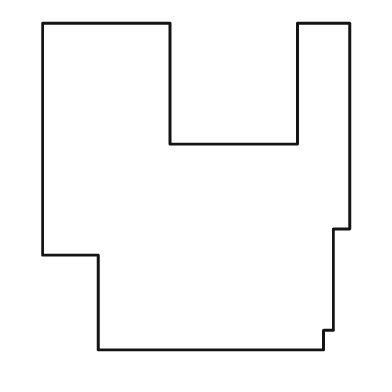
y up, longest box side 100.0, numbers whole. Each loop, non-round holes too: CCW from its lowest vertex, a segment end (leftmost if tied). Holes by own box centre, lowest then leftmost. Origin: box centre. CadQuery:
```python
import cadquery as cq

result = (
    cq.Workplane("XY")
    .moveTo(-30.0, -50.0)
    .lineTo(39.0, -50.0)
    .lineTo(39.0, -44.0)
    .lineTo(42.0, -44.0)
    .lineTo(42.0, -13.0)
    .lineTo(47.0, -13.0)
    .lineTo(47.0, 50.0)
    .lineTo(31.0, 50.0)
    .lineTo(31.0, 13.0)
    .lineTo(-8.0, 13.0)
    .lineTo(-8.0, 50.0)
    .lineTo(-47.0, 50.0)
    .lineTo(-47.0, -21.0)
    .lineTo(-30.0, -21.0)
    .close()
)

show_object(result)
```